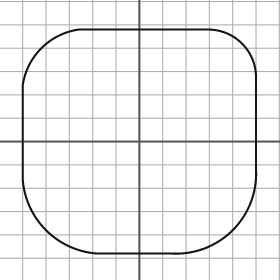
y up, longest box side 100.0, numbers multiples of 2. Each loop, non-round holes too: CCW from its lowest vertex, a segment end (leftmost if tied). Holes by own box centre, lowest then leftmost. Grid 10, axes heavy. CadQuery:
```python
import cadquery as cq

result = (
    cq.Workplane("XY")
    .moveTo(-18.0, -48.0)
    .lineTo(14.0, -48.0)
    .threePointArc((40.0, -38.0), (50.0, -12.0))
    .lineTo(50.0, 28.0)
    .threePointArc((44.0, 42.0), (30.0, 48.0))
    .lineTo(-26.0, 48.0)
    .threePointArc((-42.0, 40.0), (-50.0, 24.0))
    .lineTo(-50.0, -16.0)
    .threePointArc((-40.0, -38.0), (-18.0, -48.0))
    .close()
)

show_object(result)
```